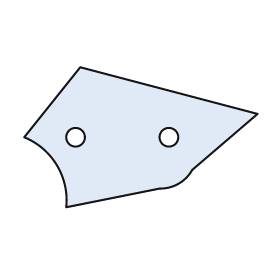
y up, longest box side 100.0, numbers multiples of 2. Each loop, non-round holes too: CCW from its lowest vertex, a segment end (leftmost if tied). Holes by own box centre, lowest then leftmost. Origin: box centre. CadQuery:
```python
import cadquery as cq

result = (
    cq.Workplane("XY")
    .moveTo(-32.0, -30.0)
    .lineTo(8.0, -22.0)
    .threePointArc((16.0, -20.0), (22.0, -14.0))
    .lineTo(50.0, 10.0)
    .lineTo(-26.0, 30.0)
    .lineTo(-50.0, 0.0)
    .threePointArc((-36.0, -12.0), (-32.0, -30.0))
    .close()
    .moveTo(-28.0, 0.0)
    .circle(4.0)
    .moveTo(12.0, 0.0)
    .circle(4.0)
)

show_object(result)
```